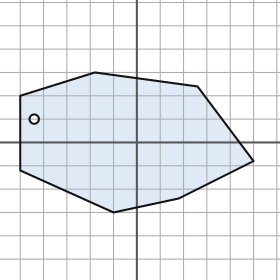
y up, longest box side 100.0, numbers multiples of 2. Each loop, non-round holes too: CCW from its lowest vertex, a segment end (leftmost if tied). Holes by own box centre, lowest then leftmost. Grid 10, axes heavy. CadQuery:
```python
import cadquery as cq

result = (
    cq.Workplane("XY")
    .moveTo(-10.0, -30.0)
    .lineTo(18.0, -24.0)
    .lineTo(50.0, -8.0)
    .lineTo(26.0, 24.0)
    .lineTo(-18.0, 30.0)
    .lineTo(-50.0, 20.0)
    .lineTo(-50.0, -12.0)
    .close()
    .moveTo(-44.0, 10.0)
    .circle(2.0)
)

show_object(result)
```